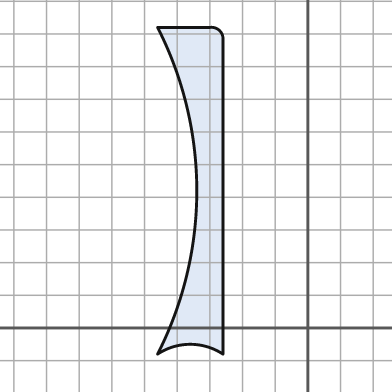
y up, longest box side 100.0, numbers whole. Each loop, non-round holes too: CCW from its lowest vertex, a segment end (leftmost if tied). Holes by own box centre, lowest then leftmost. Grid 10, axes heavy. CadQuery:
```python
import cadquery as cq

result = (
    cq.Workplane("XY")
    .moveTo(-46.0, -8.0)
    .threePointArc((-36.0, -5.0), (-26.0, -8.0))
    .lineTo(-26.0, 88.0)
    .threePointArc((-27.0, 91.0), (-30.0, 92.0))
    .lineTo(-46.0, 92.0)
    .threePointArc((-34.0, 42.0), (-46.0, -8.0))
    .close()
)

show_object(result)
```